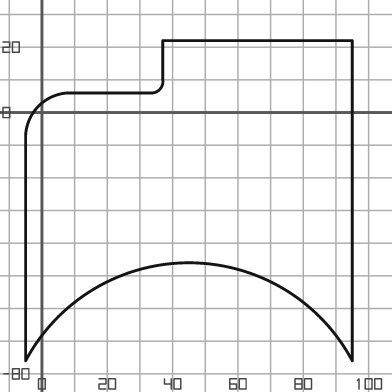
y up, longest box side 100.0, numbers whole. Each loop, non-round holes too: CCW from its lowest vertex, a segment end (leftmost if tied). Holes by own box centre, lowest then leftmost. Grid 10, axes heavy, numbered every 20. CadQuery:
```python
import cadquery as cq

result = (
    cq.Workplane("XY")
    .moveTo(-5.0, -76.0)
    .threePointArc((45.0, -46.0), (95.0, -76.0))
    .lineTo(95.0, 22.0)
    .lineTo(37.0, 22.0)
    .lineTo(37.0, 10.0)
    .threePointArc((36.0, 7.0), (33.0, 6.0))
    .lineTo(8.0, 6.0)
    .threePointArc((-1.0, 2.0), (-5.0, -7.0))
    .close()
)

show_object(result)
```